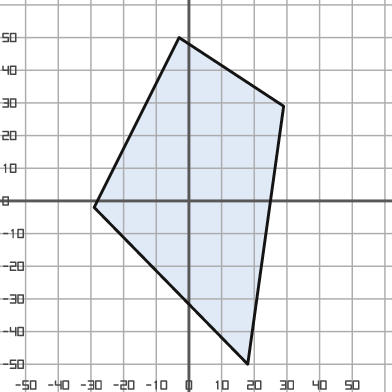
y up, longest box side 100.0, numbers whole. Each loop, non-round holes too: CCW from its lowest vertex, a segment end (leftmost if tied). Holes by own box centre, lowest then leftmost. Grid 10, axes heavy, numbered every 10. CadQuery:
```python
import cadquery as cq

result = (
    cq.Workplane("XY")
    .moveTo(18.0, -50.0)
    .lineTo(29.0, 29.0)
    .lineTo(-3.0, 50.0)
    .lineTo(-29.0, -2.0)
    .close()
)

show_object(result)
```